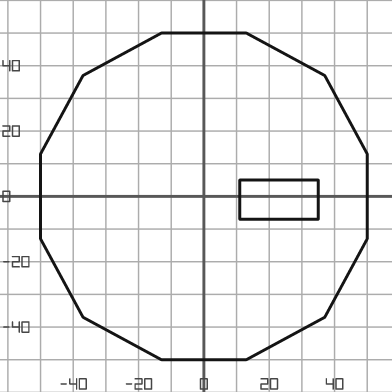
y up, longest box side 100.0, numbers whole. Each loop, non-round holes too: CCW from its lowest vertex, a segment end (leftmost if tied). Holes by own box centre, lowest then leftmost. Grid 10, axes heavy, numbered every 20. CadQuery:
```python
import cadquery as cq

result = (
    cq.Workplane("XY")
    .moveTo(-13.0, -50.0)
    .lineTo(13.0, -50.0)
    .lineTo(37.0, -37.0)
    .lineTo(50.0, -13.0)
    .lineTo(50.0, 13.0)
    .lineTo(37.0, 37.0)
    .lineTo(13.0, 50.0)
    .lineTo(-13.0, 50.0)
    .lineTo(-37.0, 37.0)
    .lineTo(-50.0, 13.0)
    .lineTo(-50.0, -13.0)
    .lineTo(-37.0, -37.0)
    .close()
    .moveTo(11.0, -7.0)
    .lineTo(35.0, -7.0)
    .lineTo(35.0, 5.0)
    .lineTo(11.0, 5.0)
    .close()
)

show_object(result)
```